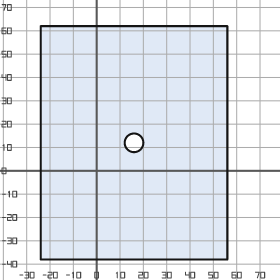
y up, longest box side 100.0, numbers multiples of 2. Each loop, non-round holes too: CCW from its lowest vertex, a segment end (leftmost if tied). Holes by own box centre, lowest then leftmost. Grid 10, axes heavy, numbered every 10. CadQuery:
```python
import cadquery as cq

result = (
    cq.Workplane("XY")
    .moveTo(-24.0, -38.0)
    .lineTo(56.0, -38.0)
    .lineTo(56.0, 62.0)
    .lineTo(-24.0, 62.0)
    .close()
    .moveTo(16.0, 12.0)
    .circle(4.0)
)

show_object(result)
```